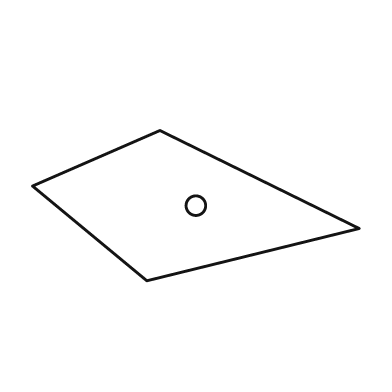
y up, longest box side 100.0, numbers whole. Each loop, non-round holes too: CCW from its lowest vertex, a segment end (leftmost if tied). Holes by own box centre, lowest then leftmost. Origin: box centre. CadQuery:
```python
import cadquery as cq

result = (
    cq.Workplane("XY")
    .moveTo(-15.0, -23.0)
    .lineTo(50.0, -7.0)
    .lineTo(-11.0, 23.0)
    .lineTo(-50.0, 6.0)
    .close()
    .moveTo(0.0, 0.0)
    .circle(3.0)
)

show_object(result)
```